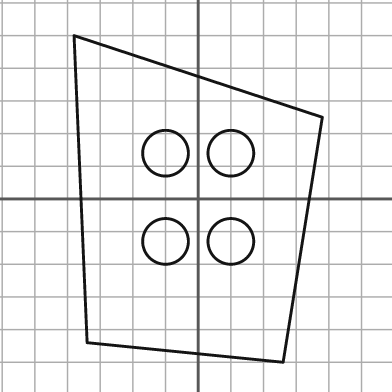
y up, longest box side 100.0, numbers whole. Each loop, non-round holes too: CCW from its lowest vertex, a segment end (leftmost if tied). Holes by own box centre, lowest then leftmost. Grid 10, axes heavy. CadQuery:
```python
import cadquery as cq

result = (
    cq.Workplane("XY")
    .moveTo(26.0, -50.0)
    .lineTo(38.0, 25.0)
    .lineTo(-38.0, 50.0)
    .lineTo(-34.0, -44.0)
    .close()
    .moveTo(-10.0, -13.0)
    .circle(7.0)
    .moveTo(10.0, -13.0)
    .circle(7.0)
    .moveTo(-10.0, 14.0)
    .circle(7.0)
    .moveTo(10.0, 14.0)
    .circle(7.0)
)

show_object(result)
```